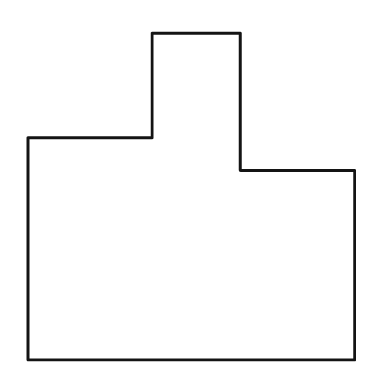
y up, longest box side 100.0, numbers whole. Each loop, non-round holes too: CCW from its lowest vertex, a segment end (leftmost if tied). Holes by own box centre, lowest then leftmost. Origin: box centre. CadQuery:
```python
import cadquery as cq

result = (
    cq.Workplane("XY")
    .moveTo(-50.0, -50.0)
    .lineTo(50.0, -50.0)
    .lineTo(50.0, 8.0)
    .lineTo(15.0, 8.0)
    .lineTo(15.0, 50.0)
    .lineTo(-12.0, 50.0)
    .lineTo(-12.0, 18.0)
    .lineTo(-50.0, 18.0)
    .close()
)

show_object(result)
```